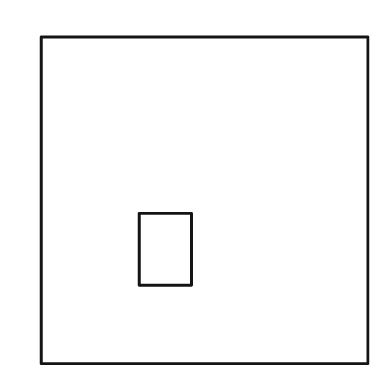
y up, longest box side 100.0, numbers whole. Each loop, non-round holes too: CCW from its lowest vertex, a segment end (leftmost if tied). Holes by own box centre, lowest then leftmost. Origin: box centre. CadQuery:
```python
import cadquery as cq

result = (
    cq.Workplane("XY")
    .moveTo(-50.0, -50.0)
    .lineTo(50.0, -50.0)
    .lineTo(50.0, 50.0)
    .lineTo(-50.0, 50.0)
    .close()
    .moveTo(-20.0, -26.0)
    .lineTo(-4.0, -26.0)
    .lineTo(-4.0, -4.0)
    .lineTo(-20.0, -4.0)
    .close()
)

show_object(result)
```